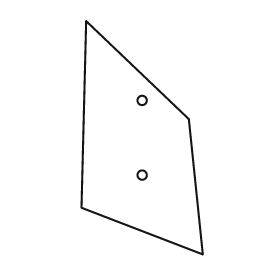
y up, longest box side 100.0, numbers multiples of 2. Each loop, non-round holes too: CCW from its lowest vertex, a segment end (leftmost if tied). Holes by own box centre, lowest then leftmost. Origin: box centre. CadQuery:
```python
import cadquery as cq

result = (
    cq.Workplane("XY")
    .moveTo(26.0, -50.0)
    .lineTo(20.0, 8.0)
    .lineTo(-24.0, 50.0)
    .lineTo(-26.0, -30.0)
    .close()
    .moveTo(0.0, -16.0)
    .circle(2.0)
    .moveTo(0.0, 16.0)
    .circle(2.0)
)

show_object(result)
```